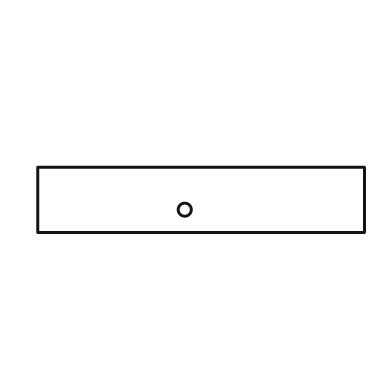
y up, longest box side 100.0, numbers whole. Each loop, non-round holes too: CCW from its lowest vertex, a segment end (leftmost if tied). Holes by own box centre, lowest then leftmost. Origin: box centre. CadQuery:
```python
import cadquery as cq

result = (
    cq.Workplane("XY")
    .moveTo(-50.0, -10.0)
    .lineTo(50.0, -10.0)
    .lineTo(50.0, 10.0)
    .lineTo(-50.0, 10.0)
    .close()
    .moveTo(-5.0, -3.0)
    .circle(2.0)
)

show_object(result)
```